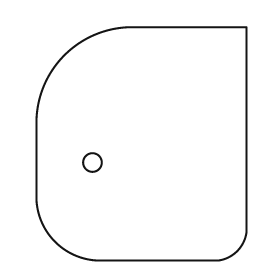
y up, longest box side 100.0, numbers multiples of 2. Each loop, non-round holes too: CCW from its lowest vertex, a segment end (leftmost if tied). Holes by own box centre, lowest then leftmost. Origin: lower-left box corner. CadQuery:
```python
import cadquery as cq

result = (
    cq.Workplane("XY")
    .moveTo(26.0, 0.0)
    .lineTo(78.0, 0.0)
    .threePointArc((86.0, 4.0), (90.0, 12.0))
    .lineTo(90.0, 100.0)
    .lineTo(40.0, 100.0)
    .threePointArc((12.0, 88.0), (0.0, 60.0))
    .lineTo(0.0, 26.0)
    .threePointArc((8.0, 8.0), (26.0, 0.0))
    .close()
    .moveTo(24.0, 42.0)
    .circle(4.0)
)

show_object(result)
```